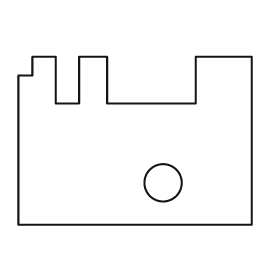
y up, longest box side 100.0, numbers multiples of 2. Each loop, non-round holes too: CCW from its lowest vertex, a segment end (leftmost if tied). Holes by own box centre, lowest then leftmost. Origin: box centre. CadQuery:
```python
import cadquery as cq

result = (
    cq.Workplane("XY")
    .moveTo(-50.0, -36.0)
    .lineTo(50.0, -36.0)
    .lineTo(50.0, 36.0)
    .lineTo(26.0, 36.0)
    .lineTo(26.0, 16.0)
    .lineTo(-12.0, 16.0)
    .lineTo(-12.0, 36.0)
    .lineTo(-24.0, 36.0)
    .lineTo(-24.0, 16.0)
    .lineTo(-34.0, 16.0)
    .lineTo(-34.0, 36.0)
    .lineTo(-44.0, 36.0)
    .lineTo(-44.0, 28.0)
    .lineTo(-50.0, 28.0)
    .close()
    .moveTo(12.0, -18.0)
    .circle(8.0)
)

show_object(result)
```